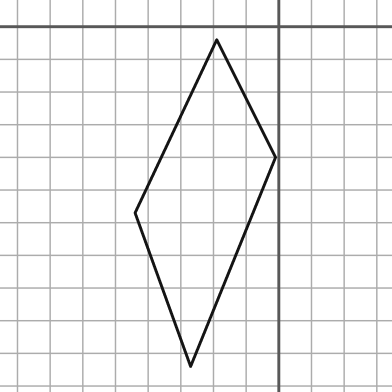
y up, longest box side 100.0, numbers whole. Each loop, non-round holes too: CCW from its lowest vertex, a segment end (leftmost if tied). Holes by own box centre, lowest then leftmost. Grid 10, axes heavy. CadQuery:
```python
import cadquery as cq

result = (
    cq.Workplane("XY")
    .moveTo(-27.0, -104.0)
    .lineTo(-1.0, -40.0)
    .lineTo(-19.0, -4.0)
    .lineTo(-44.0, -57.0)
    .close()
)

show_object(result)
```